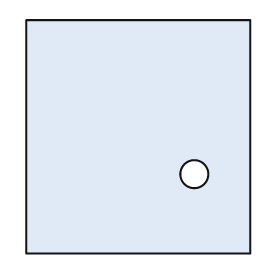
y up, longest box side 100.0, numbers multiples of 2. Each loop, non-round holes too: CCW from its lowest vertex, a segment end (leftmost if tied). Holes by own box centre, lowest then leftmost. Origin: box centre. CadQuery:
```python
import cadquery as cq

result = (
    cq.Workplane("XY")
    .moveTo(-48.0, -50.0)
    .lineTo(48.0, -50.0)
    .lineTo(48.0, 50.0)
    .lineTo(-48.0, 50.0)
    .close()
    .moveTo(24.0, -16.0)
    .circle(6.0)
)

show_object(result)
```